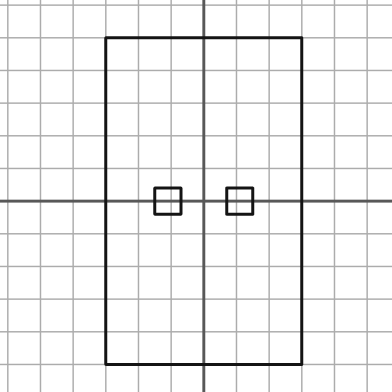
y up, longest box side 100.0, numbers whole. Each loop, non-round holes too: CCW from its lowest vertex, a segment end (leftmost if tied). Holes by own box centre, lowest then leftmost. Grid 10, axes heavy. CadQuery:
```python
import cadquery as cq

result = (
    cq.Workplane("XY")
    .moveTo(-30.0, -50.0)
    .lineTo(30.0, -50.0)
    .lineTo(30.0, 50.0)
    .lineTo(-30.0, 50.0)
    .close()
    .moveTo(-15.0, -4.0)
    .lineTo(-7.0, -4.0)
    .lineTo(-7.0, 4.0)
    .lineTo(-15.0, 4.0)
    .close()
    .moveTo(7.0, -4.0)
    .lineTo(15.0, -4.0)
    .lineTo(15.0, 4.0)
    .lineTo(7.0, 4.0)
    .close()
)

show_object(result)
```